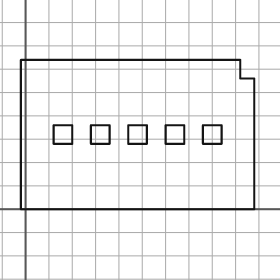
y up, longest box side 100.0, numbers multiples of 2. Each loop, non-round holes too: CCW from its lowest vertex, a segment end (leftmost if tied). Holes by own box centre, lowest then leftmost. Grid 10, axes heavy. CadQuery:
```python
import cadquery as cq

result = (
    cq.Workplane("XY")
    .moveTo(-2.0, 0.0)
    .lineTo(98.0, 0.0)
    .lineTo(98.0, 56.0)
    .lineTo(92.0, 56.0)
    .lineTo(92.0, 64.0)
    .lineTo(-2.0, 64.0)
    .close()
    .moveTo(12.0, 28.0)
    .lineTo(20.0, 28.0)
    .lineTo(20.0, 36.0)
    .lineTo(12.0, 36.0)
    .close()
    .moveTo(28.0, 28.0)
    .lineTo(36.0, 28.0)
    .lineTo(36.0, 36.0)
    .lineTo(28.0, 36.0)
    .close()
    .moveTo(44.0, 28.0)
    .lineTo(52.0, 28.0)
    .lineTo(52.0, 36.0)
    .lineTo(44.0, 36.0)
    .close()
    .moveTo(60.0, 28.0)
    .lineTo(68.0, 28.0)
    .lineTo(68.0, 36.0)
    .lineTo(60.0, 36.0)
    .close()
    .moveTo(76.0, 28.0)
    .lineTo(84.0, 28.0)
    .lineTo(84.0, 36.0)
    .lineTo(76.0, 36.0)
    .close()
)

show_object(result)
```